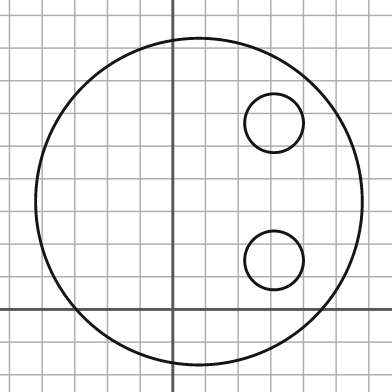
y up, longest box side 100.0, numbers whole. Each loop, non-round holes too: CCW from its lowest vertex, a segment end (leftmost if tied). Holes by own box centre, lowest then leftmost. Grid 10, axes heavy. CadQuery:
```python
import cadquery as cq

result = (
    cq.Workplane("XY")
    .moveTo(8.0, 33.0)
    .circle(50.0)
    .moveTo(31.0, 15.0)
    .circle(9.0)
    .moveTo(31.0, 57.0)
    .circle(9.0)
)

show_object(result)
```